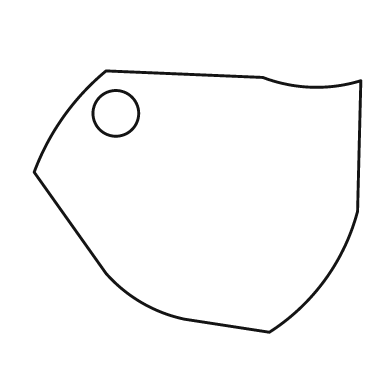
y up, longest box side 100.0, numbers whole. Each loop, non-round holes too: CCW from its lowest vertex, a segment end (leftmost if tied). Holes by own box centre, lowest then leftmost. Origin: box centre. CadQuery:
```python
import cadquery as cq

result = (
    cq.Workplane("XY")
    .moveTo(22.0, -40.0)
    .threePointArc((39.0, -24.0), (49.0, -3.0))
    .lineTo(50.0, 37.0)
    .threePointArc((35.0, 35.0), (20.0, 38.0))
    .lineTo(-28.0, 40.0)
    .threePointArc((-41.0, 26.0), (-50.0, 9.0))
    .lineTo(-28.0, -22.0)
    .threePointArc((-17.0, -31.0), (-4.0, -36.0))
    .close()
    .moveTo(-25.0, 27.0)
    .circle(7.0)
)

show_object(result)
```